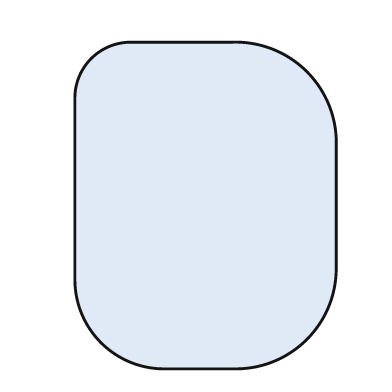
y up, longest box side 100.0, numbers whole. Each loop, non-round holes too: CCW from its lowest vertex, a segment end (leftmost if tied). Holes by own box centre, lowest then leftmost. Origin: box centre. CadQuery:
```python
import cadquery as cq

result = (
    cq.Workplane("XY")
    .moveTo(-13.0, -50.0)
    .lineTo(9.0, -50.0)
    .threePointArc((31.0, -41.0), (40.0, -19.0))
    .lineTo(40.0, 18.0)
    .threePointArc((31.0, 41.0), (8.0, 50.0))
    .lineTo(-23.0, 50.0)
    .threePointArc((-35.0, 45.0), (-40.0, 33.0))
    .lineTo(-40.0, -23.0)
    .threePointArc((-32.0, -42.0), (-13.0, -50.0))
    .close()
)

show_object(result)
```